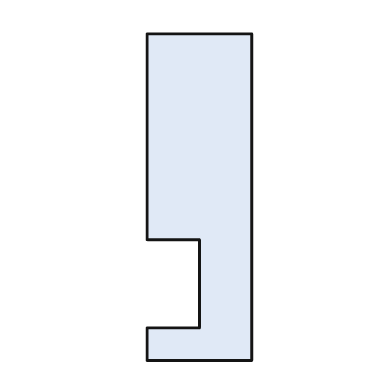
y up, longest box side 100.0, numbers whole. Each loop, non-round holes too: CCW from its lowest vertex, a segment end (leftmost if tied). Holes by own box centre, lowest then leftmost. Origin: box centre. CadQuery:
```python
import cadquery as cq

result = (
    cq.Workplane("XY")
    .moveTo(-16.0, -50.0)
    .lineTo(16.0, -50.0)
    .lineTo(16.0, 50.0)
    .lineTo(-16.0, 50.0)
    .lineTo(-16.0, -13.0)
    .lineTo(0.0, -13.0)
    .lineTo(0.0, -40.0)
    .lineTo(-16.0, -40.0)
    .close()
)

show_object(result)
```